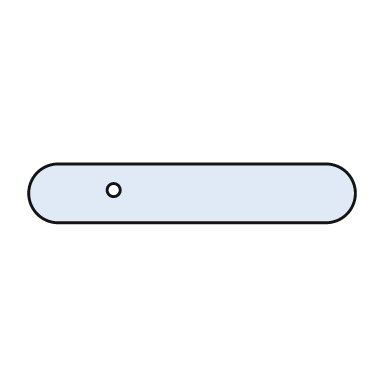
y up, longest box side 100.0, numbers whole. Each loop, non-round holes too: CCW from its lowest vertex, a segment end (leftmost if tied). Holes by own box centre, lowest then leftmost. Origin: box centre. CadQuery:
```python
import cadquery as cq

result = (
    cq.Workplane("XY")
    .moveTo(-41.0, -9.0)
    .lineTo(41.0, -9.0)
    .threePointArc((50.0, 0.0), (41.0, 9.0))
    .lineTo(-41.0, 9.0)
    .threePointArc((-50.0, 0.0), (-41.0, -9.0))
    .close()
    .moveTo(-24.0, 1.0)
    .circle(2.0)
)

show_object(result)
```